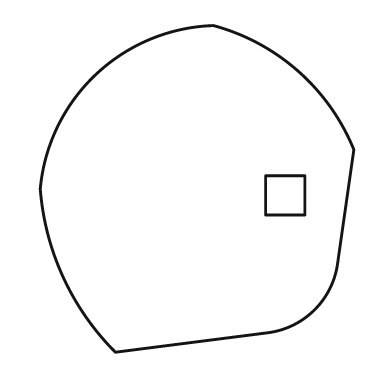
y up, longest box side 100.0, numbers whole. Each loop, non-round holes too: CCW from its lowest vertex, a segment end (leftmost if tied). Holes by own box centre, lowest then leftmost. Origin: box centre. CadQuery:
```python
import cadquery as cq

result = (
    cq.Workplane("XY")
    .moveTo(-25.0, -50.0)
    .lineTo(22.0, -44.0)
    .threePointArc((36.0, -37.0), (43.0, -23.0))
    .lineTo(48.0, 12.0)
    .threePointArc((31.0, 36.0), (5.0, 50.0))
    .threePointArc((-31.0, 35.0), (-48.0, 0.0))
    .threePointArc((-41.0, -27.0), (-25.0, -50.0))
    .close()
    .moveTo(21.0, -8.0)
    .lineTo(33.0, -8.0)
    .lineTo(33.0, 4.0)
    .lineTo(21.0, 4.0)
    .close()
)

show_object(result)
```